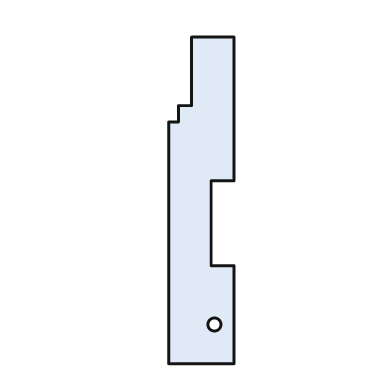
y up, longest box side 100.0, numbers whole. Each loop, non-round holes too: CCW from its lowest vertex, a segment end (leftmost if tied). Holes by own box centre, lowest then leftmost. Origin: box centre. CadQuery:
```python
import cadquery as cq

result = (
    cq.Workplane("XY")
    .moveTo(-10.0, -50.0)
    .lineTo(10.0, -50.0)
    .lineTo(10.0, -20.0)
    .lineTo(3.0, -20.0)
    .lineTo(3.0, 6.0)
    .lineTo(10.0, 6.0)
    .lineTo(10.0, 50.0)
    .lineTo(-3.0, 50.0)
    .lineTo(-3.0, 29.0)
    .lineTo(-7.0, 29.0)
    .lineTo(-7.0, 24.0)
    .lineTo(-10.0, 24.0)
    .close()
    .moveTo(4.0, -38.0)
    .circle(2.0)
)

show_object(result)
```